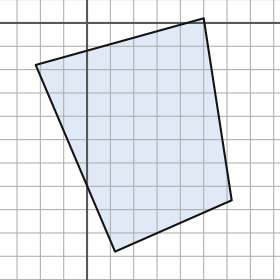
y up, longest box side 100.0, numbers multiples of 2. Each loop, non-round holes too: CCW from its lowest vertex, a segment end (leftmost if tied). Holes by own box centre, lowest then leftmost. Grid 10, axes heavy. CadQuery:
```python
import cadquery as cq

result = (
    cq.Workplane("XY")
    .moveTo(12.0, -98.0)
    .lineTo(62.0, -76.0)
    .lineTo(50.0, 2.0)
    .lineTo(-22.0, -18.0)
    .close()
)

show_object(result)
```